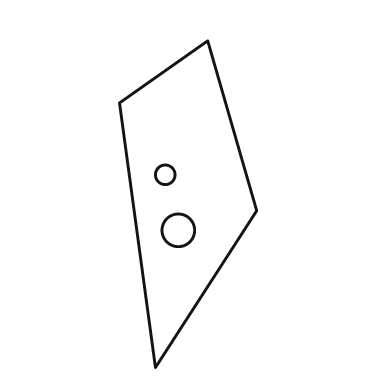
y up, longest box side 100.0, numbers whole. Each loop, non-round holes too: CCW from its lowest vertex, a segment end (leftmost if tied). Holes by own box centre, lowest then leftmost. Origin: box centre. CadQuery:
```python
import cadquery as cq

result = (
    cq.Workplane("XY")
    .moveTo(-10.0, -50.0)
    .lineTo(21.0, -2.0)
    .lineTo(6.0, 50.0)
    .lineTo(-21.0, 31.0)
    .close()
    .moveTo(-3.0, -8.0)
    .circle(5.0)
    .moveTo(-7.0, 9.0)
    .circle(3.0)
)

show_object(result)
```